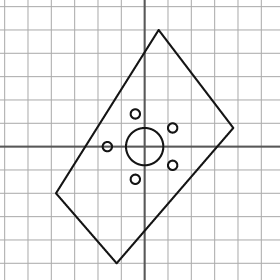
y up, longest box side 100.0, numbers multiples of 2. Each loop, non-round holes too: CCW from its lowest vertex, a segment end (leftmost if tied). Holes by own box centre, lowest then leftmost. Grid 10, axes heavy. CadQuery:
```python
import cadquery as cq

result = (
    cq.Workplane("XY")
    .moveTo(-12.0, -50.0)
    .lineTo(38.0, 8.0)
    .lineTo(6.0, 50.0)
    .lineTo(-38.0, -20.0)
    .close()
    .moveTo(-4.0, -14.0)
    .circle(2.0)
    .moveTo(12.0, -8.0)
    .circle(2.0)
    .moveTo(-16.0, 0.0)
    .circle(2.0)
    .moveTo(0.0, 0.0)
    .circle(8.0)
    .moveTo(12.0, 8.0)
    .circle(2.0)
    .moveTo(-4.0, 14.0)
    .circle(2.0)
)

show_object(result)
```